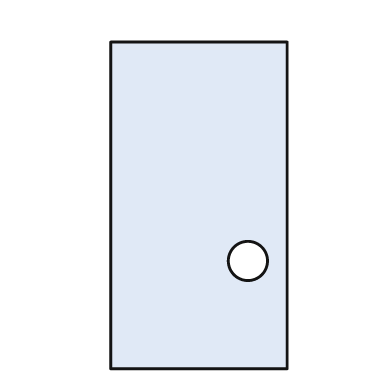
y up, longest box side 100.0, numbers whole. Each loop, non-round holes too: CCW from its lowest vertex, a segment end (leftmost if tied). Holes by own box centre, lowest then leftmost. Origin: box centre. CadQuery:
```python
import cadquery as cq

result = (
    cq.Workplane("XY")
    .moveTo(-27.0, -50.0)
    .lineTo(27.0, -50.0)
    .lineTo(27.0, 50.0)
    .lineTo(-27.0, 50.0)
    .close()
    .moveTo(15.0, -17.0)
    .circle(6.0)
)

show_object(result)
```